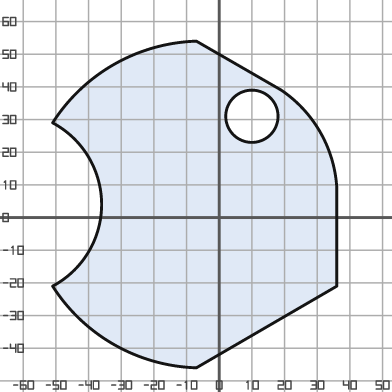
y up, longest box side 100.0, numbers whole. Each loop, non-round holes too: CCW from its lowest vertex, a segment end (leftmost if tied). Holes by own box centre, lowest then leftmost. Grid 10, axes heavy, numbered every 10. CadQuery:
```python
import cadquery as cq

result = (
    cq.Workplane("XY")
    .moveTo(-7.0, -46.0)
    .lineTo(36.0, -21.0)
    .lineTo(36.0, 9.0)
    .threePointArc((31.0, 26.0), (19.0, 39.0))
    .lineTo(-7.0, 54.0)
    .threePointArc((-32.0, 47.0), (-51.0, 29.0))
    .threePointArc((-36.0, 4.0), (-51.0, -21.0))
    .threePointArc((-32.0, -39.0), (-7.0, -46.0))
    .close()
    .moveTo(10.0, 31.0)
    .circle(8.0)
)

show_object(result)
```